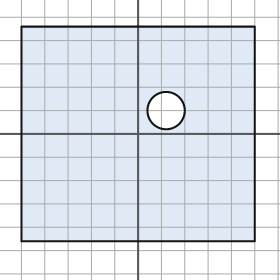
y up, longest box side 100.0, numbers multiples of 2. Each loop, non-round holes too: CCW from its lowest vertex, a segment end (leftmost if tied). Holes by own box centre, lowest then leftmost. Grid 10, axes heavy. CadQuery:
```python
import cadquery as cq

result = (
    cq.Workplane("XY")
    .moveTo(-50.0, -46.0)
    .lineTo(50.0, -46.0)
    .lineTo(50.0, 46.0)
    .lineTo(-50.0, 46.0)
    .close()
    .moveTo(12.0, 10.0)
    .circle(8.0)
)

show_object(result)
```